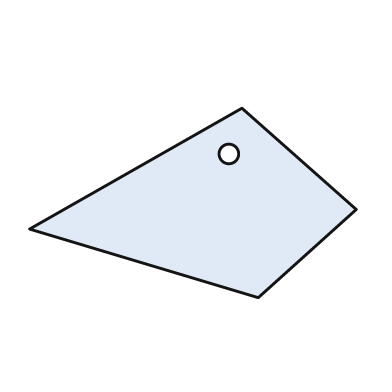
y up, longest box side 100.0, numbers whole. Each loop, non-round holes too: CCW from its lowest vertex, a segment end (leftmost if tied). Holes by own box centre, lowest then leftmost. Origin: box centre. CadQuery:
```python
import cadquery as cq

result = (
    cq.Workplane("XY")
    .moveTo(20.0, -29.0)
    .lineTo(50.0, -2.0)
    .lineTo(15.0, 29.0)
    .lineTo(-50.0, -8.0)
    .close()
    .moveTo(11.0, 15.0)
    .circle(3.0)
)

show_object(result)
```